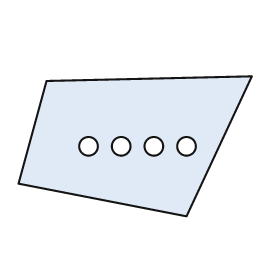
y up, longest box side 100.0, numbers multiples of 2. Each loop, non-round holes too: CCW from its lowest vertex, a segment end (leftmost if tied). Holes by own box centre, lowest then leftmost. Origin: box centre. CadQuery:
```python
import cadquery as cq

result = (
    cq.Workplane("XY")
    .moveTo(22.0, -30.0)
    .lineTo(50.0, 30.0)
    .lineTo(-38.0, 28.0)
    .lineTo(-50.0, -16.0)
    .close()
    .moveTo(-20.0, 0.0)
    .circle(4.0)
    .moveTo(-6.0, 0.0)
    .circle(4.0)
    .moveTo(8.0, 0.0)
    .circle(4.0)
    .moveTo(22.0, 0.0)
    .circle(4.0)
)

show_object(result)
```